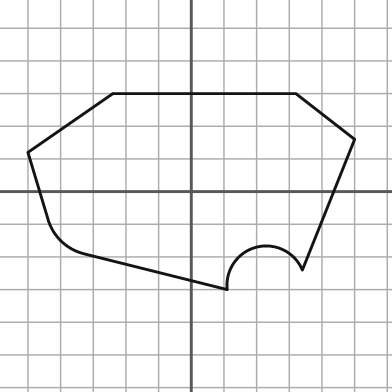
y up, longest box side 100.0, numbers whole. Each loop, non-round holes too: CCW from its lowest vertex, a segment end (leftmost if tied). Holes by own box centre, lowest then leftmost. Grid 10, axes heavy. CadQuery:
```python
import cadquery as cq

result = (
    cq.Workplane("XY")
    .moveTo(11.0, -30.0)
    .threePointArc((20.0, -17.0), (34.0, -24.0))
    .lineTo(50.0, 16.0)
    .lineTo(32.0, 30.0)
    .lineTo(-24.0, 30.0)
    .lineTo(-50.0, 12.0)
    .lineTo(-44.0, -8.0)
    .threePointArc((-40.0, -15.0), (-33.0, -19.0))
    .close()
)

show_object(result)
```